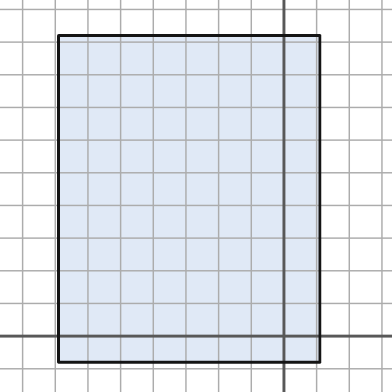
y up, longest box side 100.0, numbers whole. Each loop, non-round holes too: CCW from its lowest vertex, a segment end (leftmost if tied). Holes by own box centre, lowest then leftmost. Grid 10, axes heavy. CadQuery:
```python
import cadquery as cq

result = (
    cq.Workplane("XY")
    .moveTo(-69.0, -8.0)
    .lineTo(11.0, -8.0)
    .lineTo(11.0, 92.0)
    .lineTo(-69.0, 92.0)
    .close()
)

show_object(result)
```